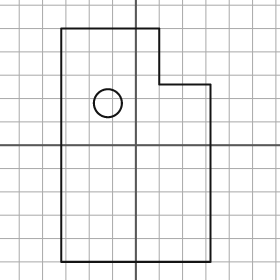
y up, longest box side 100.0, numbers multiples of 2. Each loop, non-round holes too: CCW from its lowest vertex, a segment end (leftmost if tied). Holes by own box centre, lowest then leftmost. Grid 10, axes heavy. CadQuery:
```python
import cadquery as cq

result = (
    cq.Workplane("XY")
    .moveTo(-32.0, -50.0)
    .lineTo(32.0, -50.0)
    .lineTo(32.0, 26.0)
    .lineTo(10.0, 26.0)
    .lineTo(10.0, 50.0)
    .lineTo(-32.0, 50.0)
    .close()
    .moveTo(-12.0, 18.0)
    .circle(6.0)
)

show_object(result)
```